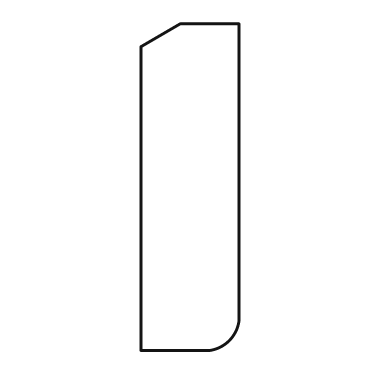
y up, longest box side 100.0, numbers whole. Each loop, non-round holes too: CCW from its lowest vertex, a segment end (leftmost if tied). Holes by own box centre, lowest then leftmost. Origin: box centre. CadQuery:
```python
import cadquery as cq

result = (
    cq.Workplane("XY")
    .moveTo(-15.0, -50.0)
    .lineTo(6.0, -50.0)
    .threePointArc((12.0, -47.0), (15.0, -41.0))
    .lineTo(15.0, 50.0)
    .lineTo(-3.0, 50.0)
    .lineTo(-15.0, 43.0)
    .close()
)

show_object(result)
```